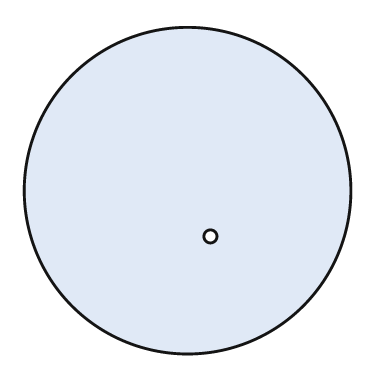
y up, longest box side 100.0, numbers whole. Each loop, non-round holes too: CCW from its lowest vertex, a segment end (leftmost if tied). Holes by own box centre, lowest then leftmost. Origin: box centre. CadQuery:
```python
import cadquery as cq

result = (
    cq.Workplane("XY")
    .moveTo(0.0, 0.0)
    .circle(50.0)
    .moveTo(7.0, -14.0)
    .circle(2.0)
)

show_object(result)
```